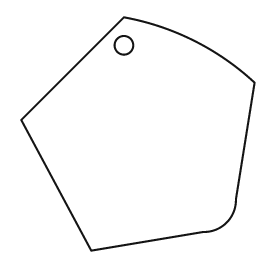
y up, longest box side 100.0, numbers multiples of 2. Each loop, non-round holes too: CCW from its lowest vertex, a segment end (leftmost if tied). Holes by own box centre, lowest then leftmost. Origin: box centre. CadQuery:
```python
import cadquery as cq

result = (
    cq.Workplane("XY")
    .moveTo(-20.0, -50.0)
    .lineTo(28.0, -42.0)
    .threePointArc((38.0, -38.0), (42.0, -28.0))
    .lineTo(50.0, 22.0)
    .threePointArc((24.0, 40.0), (-6.0, 50.0))
    .lineTo(-50.0, 6.0)
    .close()
    .moveTo(-6.0, 38.0)
    .circle(4.0)
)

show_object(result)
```